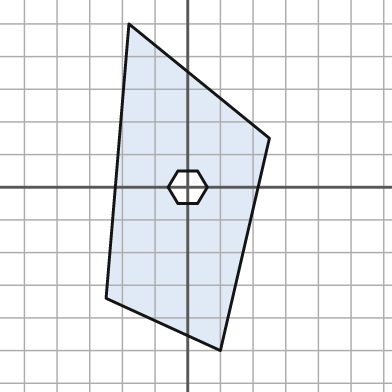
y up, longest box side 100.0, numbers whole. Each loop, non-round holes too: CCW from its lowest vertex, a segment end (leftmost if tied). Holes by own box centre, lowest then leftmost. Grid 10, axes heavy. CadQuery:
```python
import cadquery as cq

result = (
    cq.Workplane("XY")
    .moveTo(10.0, -50.0)
    .lineTo(25.0, 15.0)
    .lineTo(-18.0, 50.0)
    .lineTo(-25.0, -34.0)
    .close()
    .moveTo(-3.0, -5.0)
    .lineTo(3.0, -5.0)
    .lineTo(6.0, 0.0)
    .lineTo(3.0, 5.0)
    .lineTo(-3.0, 5.0)
    .lineTo(-6.0, 0.0)
    .close()
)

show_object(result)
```